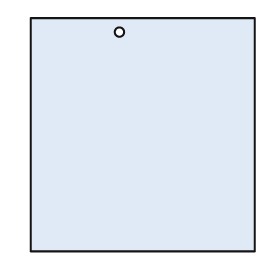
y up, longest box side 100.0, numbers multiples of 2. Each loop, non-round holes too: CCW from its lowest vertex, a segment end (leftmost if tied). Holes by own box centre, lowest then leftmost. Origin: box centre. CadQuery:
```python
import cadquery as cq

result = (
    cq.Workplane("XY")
    .moveTo(-48.0, -50.0)
    .lineTo(48.0, -50.0)
    .lineTo(48.0, 50.0)
    .lineTo(-48.0, 50.0)
    .close()
    .moveTo(-10.0, 44.0)
    .circle(2.0)
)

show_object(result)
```